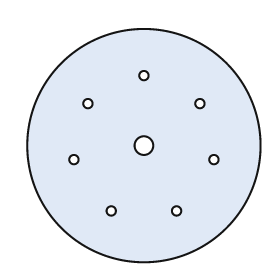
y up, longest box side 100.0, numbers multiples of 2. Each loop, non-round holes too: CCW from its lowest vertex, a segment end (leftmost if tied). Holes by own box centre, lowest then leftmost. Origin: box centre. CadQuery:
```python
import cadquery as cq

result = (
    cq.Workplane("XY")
    .moveTo(0.0, 0.0)
    .circle(50.0)
    .moveTo(-14.0, -28.0)
    .circle(2.0)
    .moveTo(14.0, -28.0)
    .circle(2.0)
    .moveTo(-30.0, -6.0)
    .circle(2.0)
    .moveTo(30.0, -6.0)
    .circle(2.0)
    .moveTo(0.0, 0.0)
    .circle(4.0)
    .moveTo(-24.0, 18.0)
    .circle(2.0)
    .moveTo(24.0, 18.0)
    .circle(2.0)
    .moveTo(0.0, 30.0)
    .circle(2.0)
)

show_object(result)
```